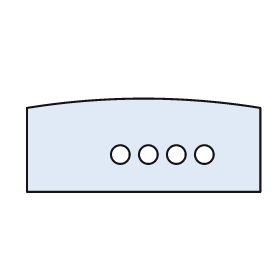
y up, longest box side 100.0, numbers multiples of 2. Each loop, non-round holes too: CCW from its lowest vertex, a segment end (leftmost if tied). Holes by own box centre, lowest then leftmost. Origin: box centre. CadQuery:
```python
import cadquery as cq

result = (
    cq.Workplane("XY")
    .moveTo(-50.0, -20.0)
    .lineTo(50.0, -20.0)
    .lineTo(50.0, 16.0)
    .threePointArc((0.0, 20.0), (-50.0, 16.0))
    .close()
    .moveTo(-10.0, -4.0)
    .circle(4.0)
    .moveTo(2.0, -4.0)
    .circle(4.0)
    .moveTo(14.0, -4.0)
    .circle(4.0)
    .moveTo(26.0, -4.0)
    .circle(4.0)
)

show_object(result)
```